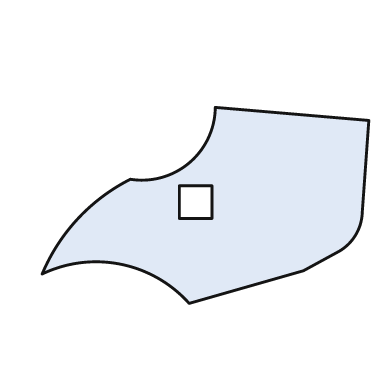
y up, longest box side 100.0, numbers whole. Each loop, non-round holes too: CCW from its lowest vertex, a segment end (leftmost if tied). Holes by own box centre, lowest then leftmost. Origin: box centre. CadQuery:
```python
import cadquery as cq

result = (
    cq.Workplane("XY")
    .moveTo(-5.0, -30.0)
    .lineTo(30.0, -20.0)
    .lineTo(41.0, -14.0)
    .threePointArc((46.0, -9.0), (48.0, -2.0))
    .lineTo(50.0, 26.0)
    .lineTo(3.0, 30.0)
    .threePointArc((-5.0, 13.0), (-23.0, 8.0))
    .threePointArc((-39.0, -4.0), (-50.0, -21.0))
    .threePointArc((-26.0, -18.0), (-5.0, -30.0))
    .close()
    .moveTo(-8.0, -4.0)
    .lineTo(2.0, -4.0)
    .lineTo(2.0, 6.0)
    .lineTo(-8.0, 6.0)
    .close()
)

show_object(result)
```